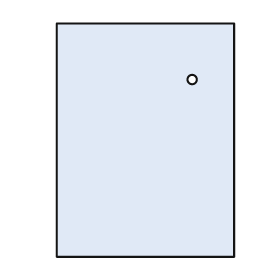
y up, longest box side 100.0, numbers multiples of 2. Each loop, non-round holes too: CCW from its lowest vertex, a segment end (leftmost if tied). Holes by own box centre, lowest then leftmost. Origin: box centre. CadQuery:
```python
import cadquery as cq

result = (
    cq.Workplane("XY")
    .moveTo(-38.0, -50.0)
    .lineTo(38.0, -50.0)
    .lineTo(38.0, 50.0)
    .lineTo(-38.0, 50.0)
    .close()
    .moveTo(20.0, 26.0)
    .circle(2.0)
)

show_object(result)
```